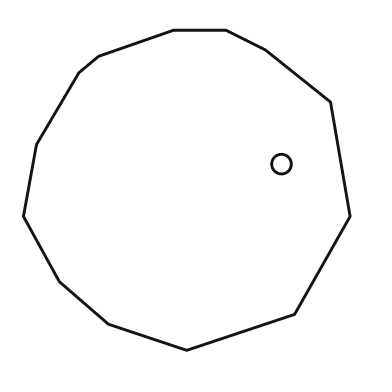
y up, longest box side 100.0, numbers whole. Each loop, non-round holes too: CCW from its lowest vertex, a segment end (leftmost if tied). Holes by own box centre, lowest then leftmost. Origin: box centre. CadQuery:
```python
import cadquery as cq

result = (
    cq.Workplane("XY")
    .moveTo(0.0, -49.0)
    .lineTo(33.0, -38.0)
    .lineTo(50.0, -8.0)
    .lineTo(44.0, 27.0)
    .lineTo(24.0, 43.0)
    .lineTo(12.0, 49.0)
    .lineTo(-4.0, 49.0)
    .lineTo(-27.0, 41.0)
    .lineTo(-33.0, 36.0)
    .lineTo(-46.0, 14.0)
    .lineTo(-50.0, -8.0)
    .lineTo(-39.0, -28.0)
    .lineTo(-24.0, -41.0)
    .close()
    .moveTo(29.0, 8.0)
    .circle(3.0)
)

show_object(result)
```